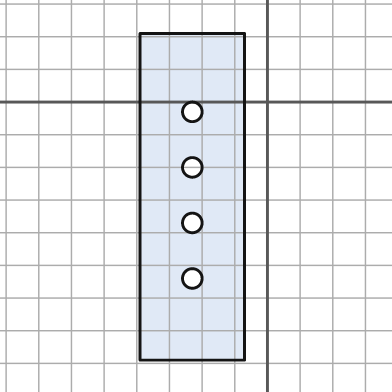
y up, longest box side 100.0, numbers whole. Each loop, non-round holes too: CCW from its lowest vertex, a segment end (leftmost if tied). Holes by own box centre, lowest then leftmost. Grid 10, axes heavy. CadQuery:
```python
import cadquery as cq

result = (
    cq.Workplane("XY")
    .moveTo(-39.0, -79.0)
    .lineTo(-7.0, -79.0)
    .lineTo(-7.0, 21.0)
    .lineTo(-39.0, 21.0)
    .close()
    .moveTo(-23.0, -54.0)
    .circle(3.0)
    .moveTo(-23.0, -37.0)
    .circle(3.0)
    .moveTo(-23.0, -20.0)
    .circle(3.0)
    .moveTo(-23.0, -3.0)
    .circle(3.0)
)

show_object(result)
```